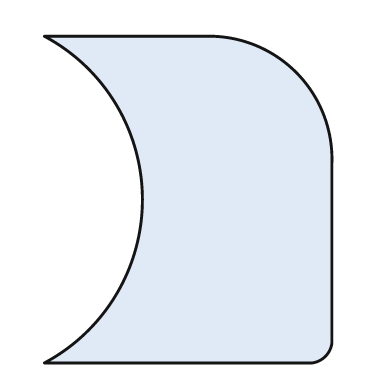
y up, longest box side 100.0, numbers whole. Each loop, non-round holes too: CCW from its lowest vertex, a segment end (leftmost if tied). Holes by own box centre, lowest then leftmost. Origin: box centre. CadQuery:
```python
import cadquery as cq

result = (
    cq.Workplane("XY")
    .moveTo(-44.0, -50.0)
    .lineTo(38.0, -50.0)
    .threePointArc((42.0, -48.0), (44.0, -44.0))
    .lineTo(44.0, 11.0)
    .threePointArc((33.0, 39.0), (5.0, 50.0))
    .lineTo(-44.0, 50.0)
    .threePointArc((-14.0, 0.0), (-44.0, -50.0))
    .close()
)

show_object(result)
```